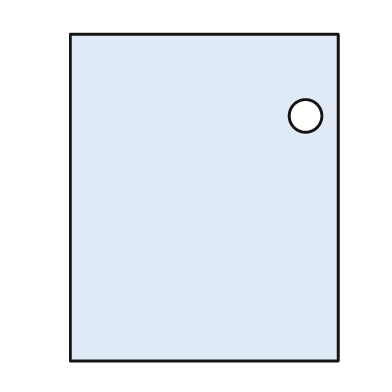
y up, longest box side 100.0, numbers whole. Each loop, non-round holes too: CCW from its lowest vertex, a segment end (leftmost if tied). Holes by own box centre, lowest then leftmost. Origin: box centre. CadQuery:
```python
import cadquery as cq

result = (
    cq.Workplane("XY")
    .moveTo(-41.0, -50.0)
    .lineTo(41.0, -50.0)
    .lineTo(41.0, 50.0)
    .lineTo(-41.0, 50.0)
    .close()
    .moveTo(31.0, 25.0)
    .circle(5.0)
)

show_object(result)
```